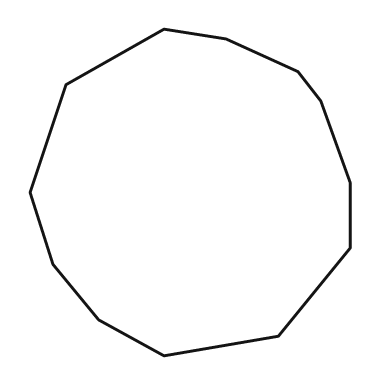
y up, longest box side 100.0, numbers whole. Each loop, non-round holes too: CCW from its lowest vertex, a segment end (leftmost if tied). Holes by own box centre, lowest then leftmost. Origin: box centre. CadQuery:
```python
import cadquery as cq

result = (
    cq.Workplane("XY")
    .moveTo(-8.0, -50.0)
    .lineTo(27.0, -44.0)
    .lineTo(49.0, -17.0)
    .lineTo(49.0, 3.0)
    .lineTo(40.0, 28.0)
    .lineTo(33.0, 37.0)
    .lineTo(11.0, 47.0)
    .lineTo(-8.0, 50.0)
    .lineTo(-38.0, 33.0)
    .lineTo(-49.0, 0.0)
    .lineTo(-42.0, -22.0)
    .lineTo(-28.0, -39.0)
    .close()
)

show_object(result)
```